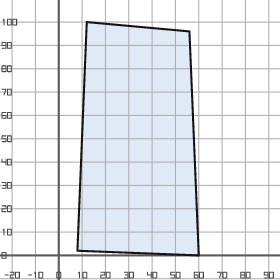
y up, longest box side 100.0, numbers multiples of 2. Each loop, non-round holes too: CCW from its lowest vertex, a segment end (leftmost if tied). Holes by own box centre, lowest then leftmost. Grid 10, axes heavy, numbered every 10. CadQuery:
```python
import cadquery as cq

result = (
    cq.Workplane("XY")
    .moveTo(60.0, 0.0)
    .lineTo(56.0, 96.0)
    .lineTo(12.0, 100.0)
    .lineTo(8.0, 2.0)
    .close()
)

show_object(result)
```